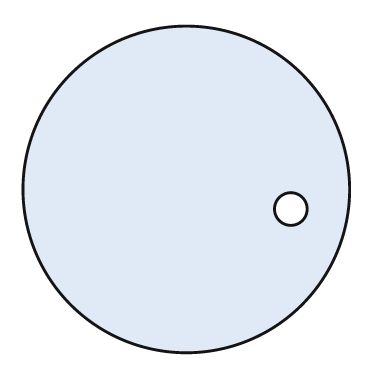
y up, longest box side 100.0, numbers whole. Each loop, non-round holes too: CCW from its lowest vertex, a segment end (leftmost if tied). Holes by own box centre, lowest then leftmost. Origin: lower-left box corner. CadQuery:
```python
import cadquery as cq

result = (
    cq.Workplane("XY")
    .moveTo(50.0, 50.0)
    .circle(50.0)
    .moveTo(82.0, 44.0)
    .circle(5.0)
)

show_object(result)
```